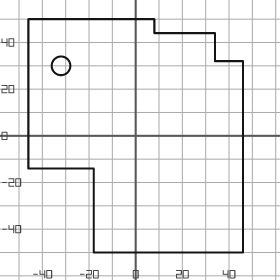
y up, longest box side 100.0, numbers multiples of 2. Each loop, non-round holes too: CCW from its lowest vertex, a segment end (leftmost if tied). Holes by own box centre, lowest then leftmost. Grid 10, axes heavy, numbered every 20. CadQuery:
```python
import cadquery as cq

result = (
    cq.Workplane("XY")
    .moveTo(-18.0, -50.0)
    .lineTo(46.0, -50.0)
    .lineTo(46.0, 32.0)
    .lineTo(34.0, 32.0)
    .lineTo(34.0, 44.0)
    .lineTo(8.0, 44.0)
    .lineTo(8.0, 50.0)
    .lineTo(-46.0, 50.0)
    .lineTo(-46.0, -14.0)
    .lineTo(-18.0, -14.0)
    .close()
    .moveTo(-32.0, 30.0)
    .circle(4.0)
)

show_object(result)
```